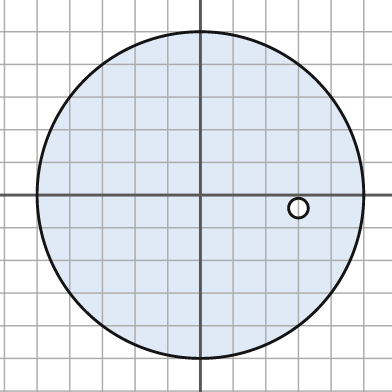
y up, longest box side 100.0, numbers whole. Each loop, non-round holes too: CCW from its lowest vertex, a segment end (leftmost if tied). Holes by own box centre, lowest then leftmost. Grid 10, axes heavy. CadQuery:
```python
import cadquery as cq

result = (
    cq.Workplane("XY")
    .moveTo(0.0, 0.0)
    .circle(50.0)
    .moveTo(30.0, -4.0)
    .circle(3.0)
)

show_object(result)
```